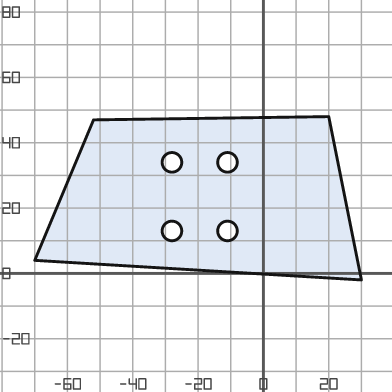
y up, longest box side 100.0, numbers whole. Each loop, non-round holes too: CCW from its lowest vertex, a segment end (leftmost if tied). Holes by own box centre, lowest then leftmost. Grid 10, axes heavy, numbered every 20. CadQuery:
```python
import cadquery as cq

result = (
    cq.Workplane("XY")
    .moveTo(30.0, -2.0)
    .lineTo(20.0, 48.0)
    .lineTo(-52.0, 47.0)
    .lineTo(-70.0, 4.0)
    .close()
    .moveTo(-28.0, 13.0)
    .circle(3.0)
    .moveTo(-11.0, 13.0)
    .circle(3.0)
    .moveTo(-28.0, 34.0)
    .circle(3.0)
    .moveTo(-11.0, 34.0)
    .circle(3.0)
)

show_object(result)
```